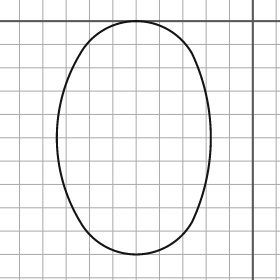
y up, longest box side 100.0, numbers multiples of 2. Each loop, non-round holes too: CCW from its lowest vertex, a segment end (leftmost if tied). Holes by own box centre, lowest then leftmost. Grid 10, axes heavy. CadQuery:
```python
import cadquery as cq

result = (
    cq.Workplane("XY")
    .moveTo(-74.0, -86.0)
    .threePointArc((-50.0, -100.0), (-26.0, -86.0))
    .threePointArc((-18.0, -50.0), (-26.0, -14.0))
    .threePointArc((-50.0, 0.0), (-74.0, -14.0))
    .threePointArc((-84.0, -50.0), (-74.0, -86.0))
    .close()
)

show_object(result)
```